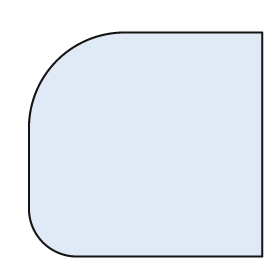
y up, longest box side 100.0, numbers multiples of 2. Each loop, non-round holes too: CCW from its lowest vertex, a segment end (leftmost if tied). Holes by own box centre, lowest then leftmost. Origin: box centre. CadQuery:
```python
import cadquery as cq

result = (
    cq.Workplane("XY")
    .moveTo(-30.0, -48.0)
    .lineTo(50.0, -48.0)
    .lineTo(50.0, 48.0)
    .lineTo(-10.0, 48.0)
    .threePointArc((-38.0, 36.0), (-50.0, 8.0))
    .lineTo(-50.0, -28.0)
    .threePointArc((-44.0, -42.0), (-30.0, -48.0))
    .close()
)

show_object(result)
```